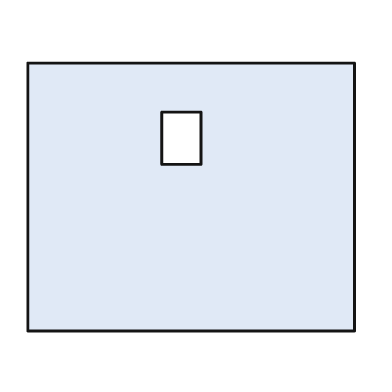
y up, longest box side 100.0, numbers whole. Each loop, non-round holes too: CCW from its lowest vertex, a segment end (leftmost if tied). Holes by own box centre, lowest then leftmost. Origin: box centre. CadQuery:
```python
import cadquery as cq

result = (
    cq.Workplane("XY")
    .moveTo(-50.0, -41.0)
    .lineTo(50.0, -41.0)
    .lineTo(50.0, 41.0)
    .lineTo(-50.0, 41.0)
    .close()
    .moveTo(-9.0, 10.0)
    .lineTo(3.0, 10.0)
    .lineTo(3.0, 26.0)
    .lineTo(-9.0, 26.0)
    .close()
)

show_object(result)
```